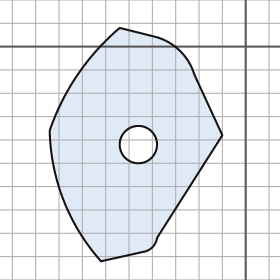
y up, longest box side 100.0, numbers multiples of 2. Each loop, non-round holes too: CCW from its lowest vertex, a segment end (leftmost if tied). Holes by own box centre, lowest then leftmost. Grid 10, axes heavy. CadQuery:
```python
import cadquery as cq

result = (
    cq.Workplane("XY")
    .moveTo(-62.0, -92.0)
    .lineTo(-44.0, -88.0)
    .threePointArc((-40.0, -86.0), (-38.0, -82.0))
    .lineTo(-10.0, -38.0)
    .lineTo(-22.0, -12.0)
    .threePointArc((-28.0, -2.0), (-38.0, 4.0))
    .lineTo(-54.0, 8.0)
    .threePointArc((-72.0, -12.0), (-84.0, -36.0))
    .threePointArc((-78.0, -66.0), (-62.0, -92.0))
    .close()
    .moveTo(-46.0, -42.0)
    .circle(8.0)
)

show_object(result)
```